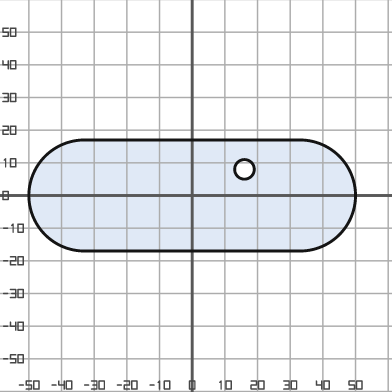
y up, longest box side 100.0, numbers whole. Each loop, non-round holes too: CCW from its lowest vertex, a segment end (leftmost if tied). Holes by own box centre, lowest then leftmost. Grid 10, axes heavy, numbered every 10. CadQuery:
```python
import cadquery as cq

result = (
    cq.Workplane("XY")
    .moveTo(-33.0, -17.0)
    .lineTo(33.0, -17.0)
    .threePointArc((50.0, 0.0), (33.0, 17.0))
    .lineTo(-33.0, 17.0)
    .threePointArc((-50.0, 0.0), (-33.0, -17.0))
    .close()
    .moveTo(16.0, 8.0)
    .circle(3.0)
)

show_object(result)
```